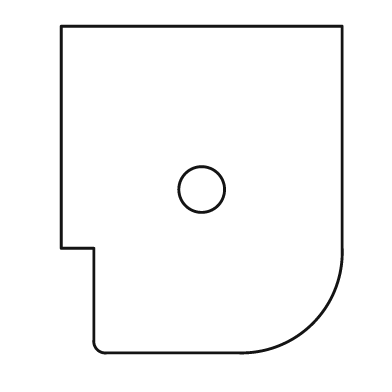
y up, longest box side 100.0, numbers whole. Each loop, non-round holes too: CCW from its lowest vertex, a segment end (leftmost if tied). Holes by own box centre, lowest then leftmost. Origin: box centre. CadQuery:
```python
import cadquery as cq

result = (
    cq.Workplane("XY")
    .moveTo(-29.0, -50.0)
    .lineTo(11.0, -50.0)
    .threePointArc((34.0, -41.0), (43.0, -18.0))
    .lineTo(43.0, 50.0)
    .lineTo(-43.0, 50.0)
    .lineTo(-43.0, -18.0)
    .lineTo(-33.0, -18.0)
    .lineTo(-33.0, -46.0)
    .threePointArc((-32.0, -49.0), (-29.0, -50.0))
    .close()
    .moveTo(0.0, 0.0)
    .circle(7.0)
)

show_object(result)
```